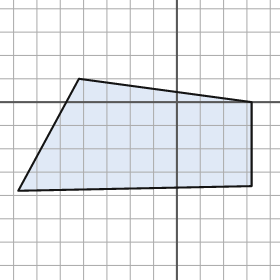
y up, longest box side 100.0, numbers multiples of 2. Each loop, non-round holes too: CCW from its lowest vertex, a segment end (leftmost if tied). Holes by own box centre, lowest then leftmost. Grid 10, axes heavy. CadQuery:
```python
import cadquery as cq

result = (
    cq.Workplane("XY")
    .moveTo(-68.0, -38.0)
    .lineTo(32.0, -36.0)
    .lineTo(32.0, 0.0)
    .lineTo(-42.0, 10.0)
    .close()
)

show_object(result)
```